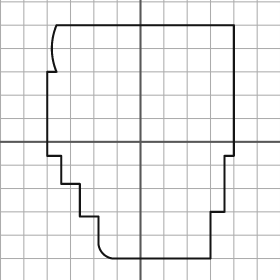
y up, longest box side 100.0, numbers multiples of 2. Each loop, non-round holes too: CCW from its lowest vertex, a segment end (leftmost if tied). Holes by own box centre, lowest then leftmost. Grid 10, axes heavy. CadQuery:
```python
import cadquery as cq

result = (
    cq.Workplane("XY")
    .moveTo(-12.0, -50.0)
    .lineTo(30.0, -50.0)
    .lineTo(30.0, -30.0)
    .lineTo(36.0, -30.0)
    .lineTo(36.0, -6.0)
    .lineTo(40.0, -6.0)
    .lineTo(40.0, 50.0)
    .lineTo(-36.0, 50.0)
    .threePointArc((-38.0, 40.0), (-36.0, 30.0))
    .lineTo(-40.0, 30.0)
    .lineTo(-40.0, -6.0)
    .lineTo(-34.0, -6.0)
    .lineTo(-34.0, -18.0)
    .lineTo(-26.0, -18.0)
    .lineTo(-26.0, -32.0)
    .lineTo(-18.0, -32.0)
    .lineTo(-18.0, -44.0)
    .threePointArc((-16.0, -48.0), (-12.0, -50.0))
    .close()
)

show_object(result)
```